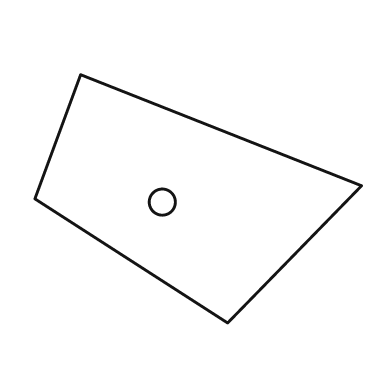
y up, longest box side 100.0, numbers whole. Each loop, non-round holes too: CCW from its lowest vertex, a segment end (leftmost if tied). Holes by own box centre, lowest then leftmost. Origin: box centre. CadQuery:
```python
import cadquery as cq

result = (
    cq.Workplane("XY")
    .moveTo(9.0, -38.0)
    .lineTo(50.0, 4.0)
    .lineTo(-36.0, 38.0)
    .lineTo(-50.0, 0.0)
    .close()
    .moveTo(-11.0, -1.0)
    .circle(4.0)
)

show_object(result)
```